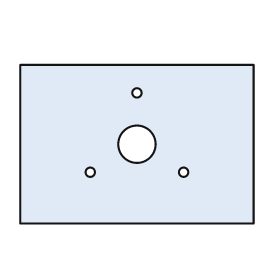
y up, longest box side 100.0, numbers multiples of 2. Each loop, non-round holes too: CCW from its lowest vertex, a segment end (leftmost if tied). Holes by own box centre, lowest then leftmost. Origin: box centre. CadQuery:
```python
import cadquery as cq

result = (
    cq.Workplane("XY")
    .moveTo(-50.0, -34.0)
    .lineTo(50.0, -34.0)
    .lineTo(50.0, 34.0)
    .lineTo(-50.0, 34.0)
    .close()
    .moveTo(-20.0, -12.0)
    .circle(2.0)
    .moveTo(20.0, -12.0)
    .circle(2.0)
    .moveTo(0.0, 0.0)
    .circle(8.0)
    .moveTo(0.0, 22.0)
    .circle(2.0)
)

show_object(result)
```